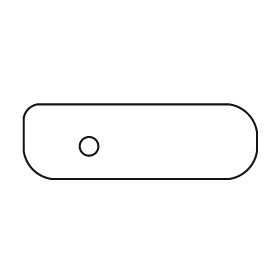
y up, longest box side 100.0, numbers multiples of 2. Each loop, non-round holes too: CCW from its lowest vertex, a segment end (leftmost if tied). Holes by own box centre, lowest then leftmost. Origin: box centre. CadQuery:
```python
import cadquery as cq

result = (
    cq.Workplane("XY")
    .moveTo(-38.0, -16.0)
    .lineTo(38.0, -16.0)
    .threePointArc((46.0, -12.0), (50.0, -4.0))
    .lineTo(50.0, 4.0)
    .threePointArc((46.0, 12.0), (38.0, 16.0))
    .lineTo(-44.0, 16.0)
    .threePointArc((-48.0, 14.0), (-50.0, 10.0))
    .lineTo(-50.0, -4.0)
    .threePointArc((-46.0, -12.0), (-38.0, -16.0))
    .close()
    .moveTo(-22.0, -2.0)
    .circle(4.0)
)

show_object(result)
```